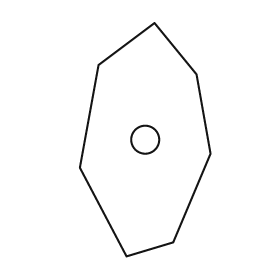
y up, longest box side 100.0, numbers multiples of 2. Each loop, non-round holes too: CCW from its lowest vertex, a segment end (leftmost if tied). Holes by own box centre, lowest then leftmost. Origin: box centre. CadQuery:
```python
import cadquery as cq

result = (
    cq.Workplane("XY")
    .moveTo(-8.0, -50.0)
    .lineTo(12.0, -44.0)
    .lineTo(28.0, -6.0)
    .lineTo(22.0, 28.0)
    .lineTo(4.0, 50.0)
    .lineTo(-20.0, 32.0)
    .lineTo(-28.0, -12.0)
    .close()
    .moveTo(0.0, 0.0)
    .circle(6.0)
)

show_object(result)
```